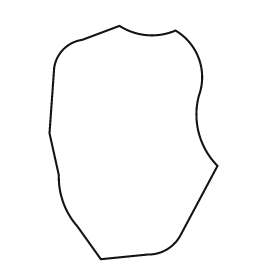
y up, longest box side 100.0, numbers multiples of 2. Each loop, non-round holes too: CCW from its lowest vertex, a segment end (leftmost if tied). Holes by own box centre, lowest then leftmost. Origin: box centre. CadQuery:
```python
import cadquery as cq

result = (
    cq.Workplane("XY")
    .moveTo(-14.0, -50.0)
    .lineTo(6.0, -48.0)
    .threePointArc((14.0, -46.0), (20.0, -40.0))
    .lineTo(36.0, -10.0)
    .threePointArc((28.0, 4.0), (28.0, 20.0))
    .threePointArc((28.0, 36.0), (18.0, 48.0))
    .threePointArc((6.0, 46.0), (-6.0, 50.0))
    .lineTo(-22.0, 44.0)
    .threePointArc((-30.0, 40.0), (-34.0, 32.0))
    .lineTo(-36.0, 4.0)
    .lineTo(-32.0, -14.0)
    .threePointArc((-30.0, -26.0), (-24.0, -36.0))
    .close()
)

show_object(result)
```